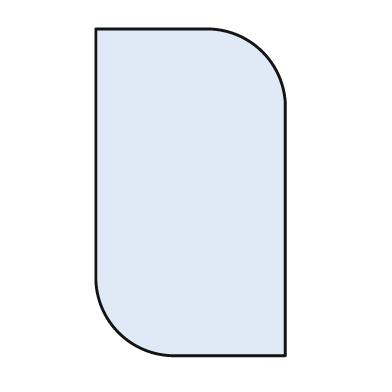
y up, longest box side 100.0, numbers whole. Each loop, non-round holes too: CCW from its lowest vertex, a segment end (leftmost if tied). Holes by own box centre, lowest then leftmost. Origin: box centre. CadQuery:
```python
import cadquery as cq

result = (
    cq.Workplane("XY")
    .moveTo(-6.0, -50.0)
    .lineTo(29.0, -50.0)
    .lineTo(29.0, 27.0)
    .threePointArc((22.0, 43.0), (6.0, 50.0))
    .lineTo(-29.0, 50.0)
    .lineTo(-29.0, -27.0)
    .threePointArc((-22.0, -43.0), (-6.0, -50.0))
    .close()
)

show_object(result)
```